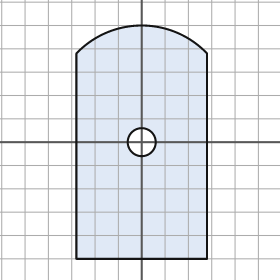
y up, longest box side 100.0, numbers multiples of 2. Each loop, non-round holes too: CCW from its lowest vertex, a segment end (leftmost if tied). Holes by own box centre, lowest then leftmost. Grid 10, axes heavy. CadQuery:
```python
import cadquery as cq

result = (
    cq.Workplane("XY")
    .moveTo(-28.0, -50.0)
    .lineTo(28.0, -50.0)
    .lineTo(28.0, 38.0)
    .threePointArc((0.0, 50.0), (-28.0, 38.0))
    .close()
    .moveTo(0.0, 0.0)
    .circle(6.0)
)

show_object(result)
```